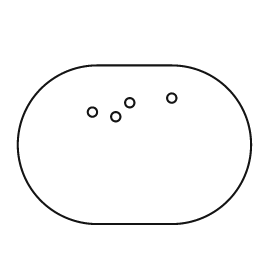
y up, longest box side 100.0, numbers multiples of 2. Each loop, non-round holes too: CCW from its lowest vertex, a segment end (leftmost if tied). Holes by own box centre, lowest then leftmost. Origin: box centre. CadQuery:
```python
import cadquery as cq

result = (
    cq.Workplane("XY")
    .moveTo(-16.0, -34.0)
    .lineTo(16.0, -34.0)
    .threePointArc((50.0, 0.0), (16.0, 34.0))
    .lineTo(-16.0, 34.0)
    .threePointArc((-50.0, 0.0), (-16.0, -34.0))
    .close()
    .moveTo(-8.0, 12.0)
    .circle(2.0)
    .moveTo(-18.0, 14.0)
    .circle(2.0)
    .moveTo(-2.0, 18.0)
    .circle(2.0)
    .moveTo(16.0, 20.0)
    .circle(2.0)
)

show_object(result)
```